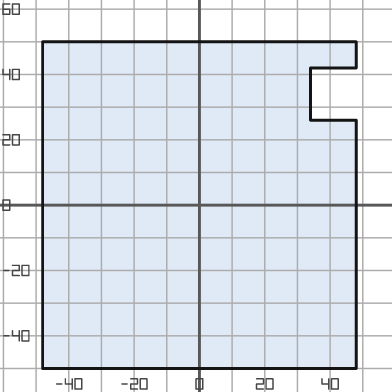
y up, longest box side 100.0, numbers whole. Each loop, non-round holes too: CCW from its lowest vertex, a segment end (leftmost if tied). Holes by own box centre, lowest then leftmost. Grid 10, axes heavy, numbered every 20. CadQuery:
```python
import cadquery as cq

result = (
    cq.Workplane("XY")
    .moveTo(-48.0, -50.0)
    .lineTo(48.0, -50.0)
    .lineTo(48.0, 26.0)
    .lineTo(34.0, 26.0)
    .lineTo(34.0, 42.0)
    .lineTo(48.0, 42.0)
    .lineTo(48.0, 50.0)
    .lineTo(-48.0, 50.0)
    .close()
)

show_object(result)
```